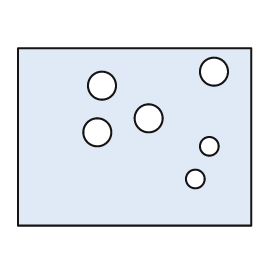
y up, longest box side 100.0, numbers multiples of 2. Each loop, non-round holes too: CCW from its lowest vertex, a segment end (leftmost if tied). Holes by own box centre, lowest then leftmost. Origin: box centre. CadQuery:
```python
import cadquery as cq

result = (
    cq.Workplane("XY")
    .moveTo(-50.0, -38.0)
    .lineTo(50.0, -38.0)
    .lineTo(50.0, 38.0)
    .lineTo(-50.0, 38.0)
    .close()
    .moveTo(26.0, -18.0)
    .circle(4.0)
    .moveTo(32.0, -4.0)
    .circle(4.0)
    .moveTo(-16.0, 2.0)
    .circle(6.0)
    .moveTo(6.0, 8.0)
    .circle(6.0)
    .moveTo(-14.0, 22.0)
    .circle(6.0)
    .moveTo(34.0, 28.0)
    .circle(6.0)
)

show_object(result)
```